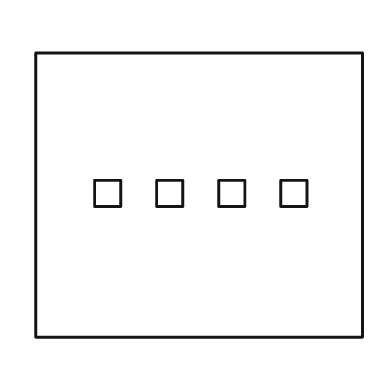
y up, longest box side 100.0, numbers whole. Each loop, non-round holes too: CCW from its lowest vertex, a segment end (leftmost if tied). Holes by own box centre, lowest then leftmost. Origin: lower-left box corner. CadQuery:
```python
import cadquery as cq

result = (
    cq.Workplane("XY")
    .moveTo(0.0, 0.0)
    .lineTo(100.0, 0.0)
    .lineTo(100.0, 87.0)
    .lineTo(0.0, 87.0)
    .close()
    .moveTo(18.0, 40.0)
    .lineTo(26.0, 40.0)
    .lineTo(26.0, 48.0)
    .lineTo(18.0, 48.0)
    .close()
    .moveTo(37.0, 40.0)
    .lineTo(45.0, 40.0)
    .lineTo(45.0, 48.0)
    .lineTo(37.0, 48.0)
    .close()
    .moveTo(56.0, 40.0)
    .lineTo(64.0, 40.0)
    .lineTo(64.0, 48.0)
    .lineTo(56.0, 48.0)
    .close()
    .moveTo(75.0, 40.0)
    .lineTo(83.0, 40.0)
    .lineTo(83.0, 48.0)
    .lineTo(75.0, 48.0)
    .close()
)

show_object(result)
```